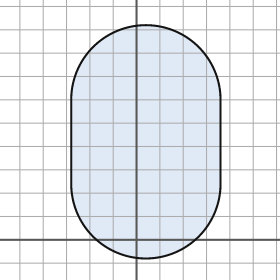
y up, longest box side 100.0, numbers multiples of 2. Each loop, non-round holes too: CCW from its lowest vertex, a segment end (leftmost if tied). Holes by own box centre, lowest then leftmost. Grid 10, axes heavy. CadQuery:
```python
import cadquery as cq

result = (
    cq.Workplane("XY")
    .moveTo(-28.0, 24.0)
    .threePointArc((4.0, -8.0), (36.0, 24.0))
    .lineTo(36.0, 60.0)
    .threePointArc((4.0, 92.0), (-28.0, 60.0))
    .close()
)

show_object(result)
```